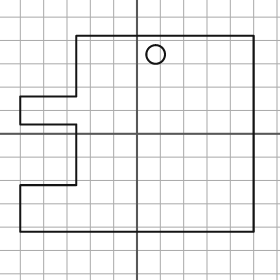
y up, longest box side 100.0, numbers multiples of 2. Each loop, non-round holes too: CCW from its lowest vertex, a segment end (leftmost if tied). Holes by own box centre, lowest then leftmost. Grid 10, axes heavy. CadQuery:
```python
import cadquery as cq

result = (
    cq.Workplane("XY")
    .moveTo(-50.0, -42.0)
    .lineTo(50.0, -42.0)
    .lineTo(50.0, 42.0)
    .lineTo(-26.0, 42.0)
    .lineTo(-26.0, 16.0)
    .lineTo(-50.0, 16.0)
    .lineTo(-50.0, 4.0)
    .lineTo(-26.0, 4.0)
    .lineTo(-26.0, -22.0)
    .lineTo(-50.0, -22.0)
    .close()
    .moveTo(8.0, 34.0)
    .circle(4.0)
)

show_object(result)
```